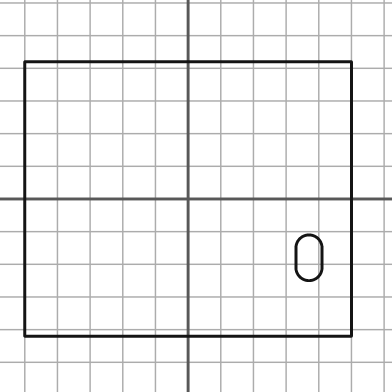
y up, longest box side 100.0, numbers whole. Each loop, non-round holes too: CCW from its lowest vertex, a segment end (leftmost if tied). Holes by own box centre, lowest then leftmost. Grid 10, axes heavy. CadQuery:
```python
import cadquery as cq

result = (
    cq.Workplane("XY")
    .moveTo(-50.0, -42.0)
    .lineTo(50.0, -42.0)
    .lineTo(50.0, 42.0)
    .lineTo(-50.0, 42.0)
    .close()
    .moveTo(33.0, -21.0)
    .threePointArc((37.0, -25.0), (41.0, -21.0))
    .lineTo(41.0, -15.0)
    .threePointArc((37.0, -11.0), (33.0, -15.0))
    .close()
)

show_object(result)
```